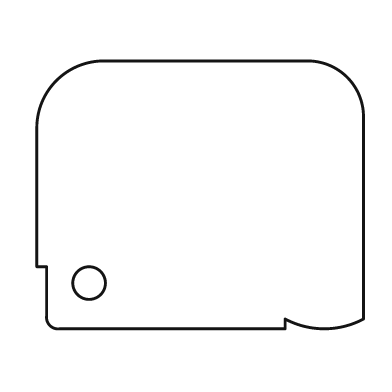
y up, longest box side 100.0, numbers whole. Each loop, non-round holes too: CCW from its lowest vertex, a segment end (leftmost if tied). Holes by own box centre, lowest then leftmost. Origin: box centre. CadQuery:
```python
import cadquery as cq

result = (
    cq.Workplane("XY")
    .moveTo(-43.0, -41.0)
    .lineTo(26.0, -41.0)
    .lineTo(26.0, -38.0)
    .threePointArc((38.0, -41.0), (50.0, -38.0))
    .lineTo(50.0, 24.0)
    .threePointArc((45.0, 36.0), (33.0, 41.0))
    .lineTo(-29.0, 41.0)
    .threePointArc((-44.0, 35.0), (-50.0, 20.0))
    .lineTo(-50.0, -22.0)
    .lineTo(-47.0, -22.0)
    .lineTo(-47.0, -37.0)
    .threePointArc((-46.0, -40.0), (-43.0, -41.0))
    .close()
    .moveTo(-34.0, -27.0)
    .circle(5.0)
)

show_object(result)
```